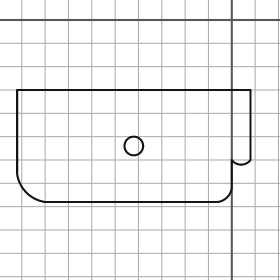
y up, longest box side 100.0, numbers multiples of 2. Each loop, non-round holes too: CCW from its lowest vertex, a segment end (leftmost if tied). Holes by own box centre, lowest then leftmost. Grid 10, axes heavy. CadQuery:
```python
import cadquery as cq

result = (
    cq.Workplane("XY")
    .moveTo(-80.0, -78.0)
    .lineTo(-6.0, -78.0)
    .threePointArc((-2.0, -76.0), (0.0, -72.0))
    .lineTo(0.0, -60.0)
    .threePointArc((4.0, -62.0), (8.0, -60.0))
    .lineTo(8.0, -30.0)
    .lineTo(-92.0, -30.0)
    .lineTo(-92.0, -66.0)
    .threePointArc((-88.0, -74.0), (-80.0, -78.0))
    .close()
    .moveTo(-42.0, -54.0)
    .circle(4.0)
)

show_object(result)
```